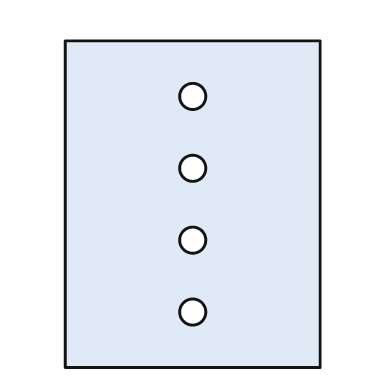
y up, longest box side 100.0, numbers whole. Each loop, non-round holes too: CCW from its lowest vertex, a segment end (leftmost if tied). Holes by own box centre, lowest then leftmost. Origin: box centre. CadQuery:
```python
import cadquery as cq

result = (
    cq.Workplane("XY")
    .moveTo(-39.0, -50.0)
    .lineTo(39.0, -50.0)
    .lineTo(39.0, 50.0)
    .lineTo(-39.0, 50.0)
    .close()
    .moveTo(0.0, -33.0)
    .circle(4.0)
    .moveTo(0.0, -11.0)
    .circle(4.0)
    .moveTo(0.0, 11.0)
    .circle(4.0)
    .moveTo(0.0, 33.0)
    .circle(4.0)
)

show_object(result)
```